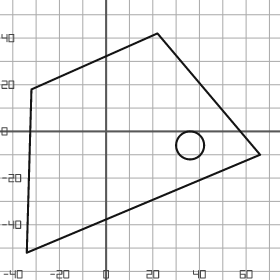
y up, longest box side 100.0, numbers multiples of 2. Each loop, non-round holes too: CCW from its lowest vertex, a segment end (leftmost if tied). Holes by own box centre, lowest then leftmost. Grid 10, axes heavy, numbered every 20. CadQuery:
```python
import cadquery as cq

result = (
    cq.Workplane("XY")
    .moveTo(-34.0, -52.0)
    .lineTo(66.0, -10.0)
    .lineTo(22.0, 42.0)
    .lineTo(-32.0, 18.0)
    .close()
    .moveTo(36.0, -6.0)
    .circle(6.0)
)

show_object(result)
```